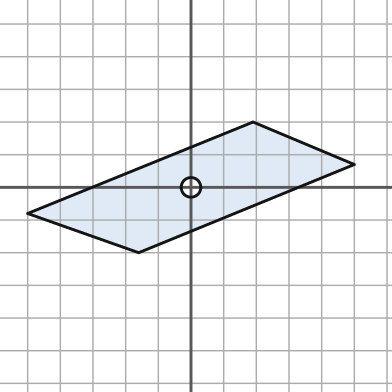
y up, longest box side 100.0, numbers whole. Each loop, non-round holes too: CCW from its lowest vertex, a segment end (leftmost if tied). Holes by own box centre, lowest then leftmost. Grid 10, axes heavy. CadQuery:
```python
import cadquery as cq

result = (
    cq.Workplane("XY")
    .moveTo(-16.0, -20.0)
    .lineTo(50.0, 7.0)
    .lineTo(19.0, 20.0)
    .lineTo(-50.0, -8.0)
    .close()
    .moveTo(0.0, 0.0)
    .circle(3.0)
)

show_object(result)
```